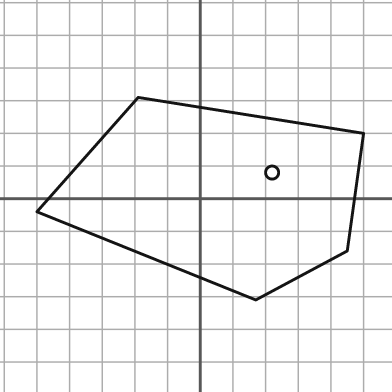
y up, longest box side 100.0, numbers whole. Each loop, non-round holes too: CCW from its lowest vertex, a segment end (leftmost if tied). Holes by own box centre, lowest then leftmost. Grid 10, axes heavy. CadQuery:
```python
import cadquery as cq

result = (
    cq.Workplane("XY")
    .moveTo(17.0, -31.0)
    .lineTo(45.0, -16.0)
    .lineTo(50.0, 20.0)
    .lineTo(-19.0, 31.0)
    .lineTo(-50.0, -4.0)
    .close()
    .moveTo(22.0, 8.0)
    .circle(2.0)
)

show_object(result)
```